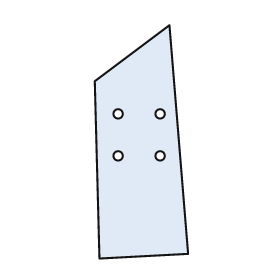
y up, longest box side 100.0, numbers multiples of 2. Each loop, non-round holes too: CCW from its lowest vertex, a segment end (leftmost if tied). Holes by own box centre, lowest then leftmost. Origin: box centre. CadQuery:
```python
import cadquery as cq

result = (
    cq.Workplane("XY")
    .moveTo(-18.0, -50.0)
    .lineTo(20.0, -48.0)
    .lineTo(12.0, 50.0)
    .lineTo(-20.0, 26.0)
    .close()
    .moveTo(-10.0, -6.0)
    .circle(2.0)
    .moveTo(8.0, -6.0)
    .circle(2.0)
    .moveTo(-10.0, 12.0)
    .circle(2.0)
    .moveTo(8.0, 12.0)
    .circle(2.0)
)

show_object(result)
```